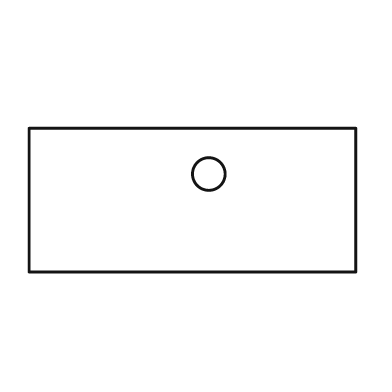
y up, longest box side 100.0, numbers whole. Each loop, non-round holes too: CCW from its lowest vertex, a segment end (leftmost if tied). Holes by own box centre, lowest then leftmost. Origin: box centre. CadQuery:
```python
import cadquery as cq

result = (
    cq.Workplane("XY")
    .moveTo(-50.0, -22.0)
    .lineTo(50.0, -22.0)
    .lineTo(50.0, 22.0)
    .lineTo(-50.0, 22.0)
    .close()
    .moveTo(5.0, 8.0)
    .circle(5.0)
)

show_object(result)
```